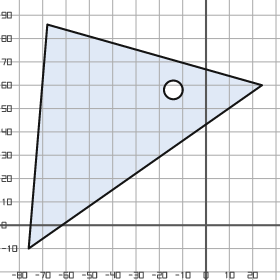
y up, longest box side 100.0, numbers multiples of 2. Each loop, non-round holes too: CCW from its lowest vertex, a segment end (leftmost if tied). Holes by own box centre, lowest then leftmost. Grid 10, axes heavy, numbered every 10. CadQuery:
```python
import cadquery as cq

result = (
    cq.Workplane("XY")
    .moveTo(-76.0, -10.0)
    .lineTo(24.0, 60.0)
    .lineTo(-68.0, 86.0)
    .close()
    .moveTo(-14.0, 58.0)
    .circle(4.0)
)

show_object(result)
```